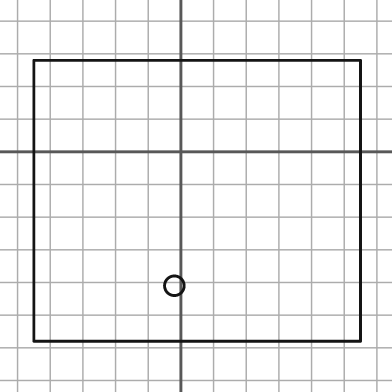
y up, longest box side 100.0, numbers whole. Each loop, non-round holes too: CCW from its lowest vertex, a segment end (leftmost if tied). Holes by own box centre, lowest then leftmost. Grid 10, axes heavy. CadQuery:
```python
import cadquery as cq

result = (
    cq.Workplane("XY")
    .moveTo(-45.0, -58.0)
    .lineTo(55.0, -58.0)
    .lineTo(55.0, 28.0)
    .lineTo(-45.0, 28.0)
    .close()
    .moveTo(-2.0, -41.0)
    .circle(3.0)
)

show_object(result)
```